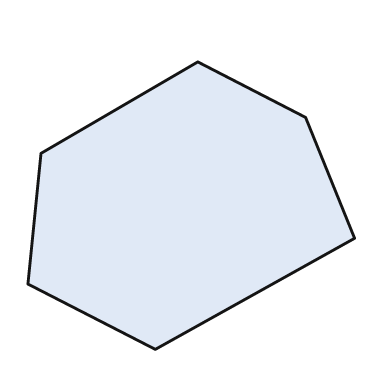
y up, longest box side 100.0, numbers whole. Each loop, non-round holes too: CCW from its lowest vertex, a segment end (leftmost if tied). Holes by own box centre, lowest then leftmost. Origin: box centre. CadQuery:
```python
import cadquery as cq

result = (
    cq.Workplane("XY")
    .moveTo(-11.0, -44.0)
    .lineTo(50.0, -10.0)
    .lineTo(35.0, 27.0)
    .lineTo(2.0, 44.0)
    .lineTo(-46.0, 16.0)
    .lineTo(-50.0, -24.0)
    .close()
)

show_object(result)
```